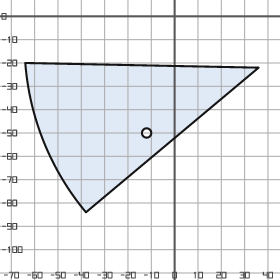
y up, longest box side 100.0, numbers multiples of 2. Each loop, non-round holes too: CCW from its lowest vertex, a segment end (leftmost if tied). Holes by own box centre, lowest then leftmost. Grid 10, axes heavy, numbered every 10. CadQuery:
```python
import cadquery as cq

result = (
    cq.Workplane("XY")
    .moveTo(-38.0, -84.0)
    .lineTo(36.0, -22.0)
    .lineTo(-64.0, -20.0)
    .threePointArc((-56.0, -54.0), (-38.0, -84.0))
    .close()
    .moveTo(-12.0, -50.0)
    .circle(2.0)
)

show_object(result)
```